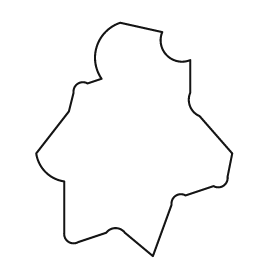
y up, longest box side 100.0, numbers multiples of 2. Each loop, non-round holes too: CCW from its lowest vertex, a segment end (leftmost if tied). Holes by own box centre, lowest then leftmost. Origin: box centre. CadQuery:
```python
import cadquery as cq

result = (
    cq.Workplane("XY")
    .moveTo(8.0, -50.0)
    .lineTo(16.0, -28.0)
    .threePointArc((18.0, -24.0), (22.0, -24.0))
    .lineTo(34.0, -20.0)
    .threePointArc((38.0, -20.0), (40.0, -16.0))
    .lineTo(42.0, -6.0)
    .lineTo(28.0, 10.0)
    .threePointArc((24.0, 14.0), (24.0, 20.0))
    .lineTo(24.0, 34.0)
    .threePointArc((14.0, 36.0), (12.0, 46.0))
    .lineTo(-6.0, 50.0)
    .threePointArc((-16.0, 40.0), (-14.0, 26.0))
    .lineTo(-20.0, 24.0)
    .threePointArc((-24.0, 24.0), (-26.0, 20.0))
    .lineTo(-28.0, 12.0)
    .lineTo(-42.0, -6.0)
    .threePointArc((-38.0, -14.0), (-30.0, -18.0))
    .lineTo(-30.0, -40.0)
    .threePointArc((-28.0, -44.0), (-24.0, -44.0))
    .lineTo(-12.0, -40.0)
    .threePointArc((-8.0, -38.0), (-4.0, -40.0))
    .close()
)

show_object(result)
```